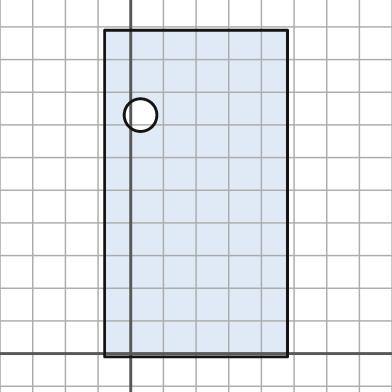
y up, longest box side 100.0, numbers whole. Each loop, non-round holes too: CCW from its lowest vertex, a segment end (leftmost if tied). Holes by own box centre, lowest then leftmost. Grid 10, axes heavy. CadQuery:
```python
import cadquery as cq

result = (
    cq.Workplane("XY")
    .moveTo(-8.0, -1.0)
    .lineTo(48.0, -1.0)
    .lineTo(48.0, 99.0)
    .lineTo(-8.0, 99.0)
    .close()
    .moveTo(3.0, 73.0)
    .circle(5.0)
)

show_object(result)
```